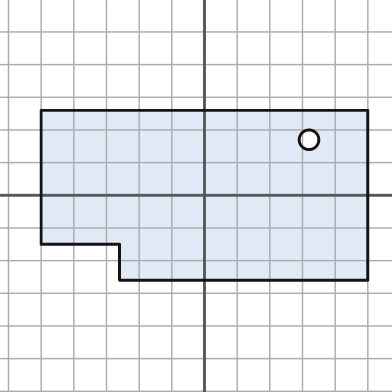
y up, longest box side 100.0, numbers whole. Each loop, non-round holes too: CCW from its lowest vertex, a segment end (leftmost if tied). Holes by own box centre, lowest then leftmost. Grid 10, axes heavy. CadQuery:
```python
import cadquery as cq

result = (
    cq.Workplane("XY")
    .moveTo(-26.0, -26.0)
    .lineTo(50.0, -26.0)
    .lineTo(50.0, 26.0)
    .lineTo(-50.0, 26.0)
    .lineTo(-50.0, -15.0)
    .lineTo(-26.0, -15.0)
    .close()
    .moveTo(32.0, 17.0)
    .circle(3.0)
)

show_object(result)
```